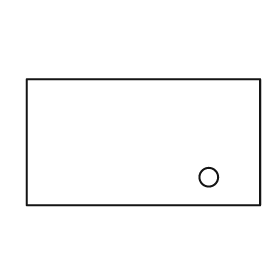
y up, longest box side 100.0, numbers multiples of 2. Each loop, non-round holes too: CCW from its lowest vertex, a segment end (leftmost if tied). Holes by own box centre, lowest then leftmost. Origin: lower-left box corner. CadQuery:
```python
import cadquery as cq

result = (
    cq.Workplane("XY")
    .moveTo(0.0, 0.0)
    .lineTo(100.0, 0.0)
    .lineTo(100.0, 54.0)
    .lineTo(0.0, 54.0)
    .close()
    .moveTo(78.0, 12.0)
    .circle(4.0)
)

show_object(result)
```